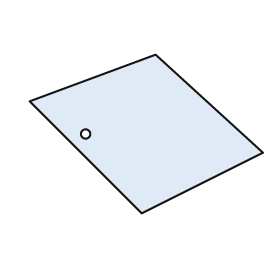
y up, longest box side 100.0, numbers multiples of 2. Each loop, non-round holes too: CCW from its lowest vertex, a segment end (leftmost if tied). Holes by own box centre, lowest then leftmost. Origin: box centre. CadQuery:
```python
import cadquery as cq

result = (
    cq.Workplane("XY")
    .moveTo(-2.0, -34.0)
    .lineTo(50.0, -8.0)
    .lineTo(4.0, 34.0)
    .lineTo(-50.0, 14.0)
    .close()
    .moveTo(-26.0, 0.0)
    .circle(2.0)
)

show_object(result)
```